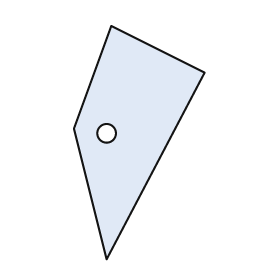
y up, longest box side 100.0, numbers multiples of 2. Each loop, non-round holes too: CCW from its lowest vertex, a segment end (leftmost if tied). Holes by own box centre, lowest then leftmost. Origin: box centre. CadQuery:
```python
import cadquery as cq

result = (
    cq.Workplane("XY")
    .moveTo(-14.0, -50.0)
    .lineTo(28.0, 30.0)
    .lineTo(-12.0, 50.0)
    .lineTo(-28.0, 6.0)
    .close()
    .moveTo(-14.0, 4.0)
    .circle(4.0)
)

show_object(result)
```